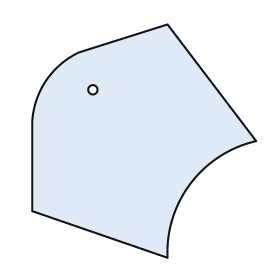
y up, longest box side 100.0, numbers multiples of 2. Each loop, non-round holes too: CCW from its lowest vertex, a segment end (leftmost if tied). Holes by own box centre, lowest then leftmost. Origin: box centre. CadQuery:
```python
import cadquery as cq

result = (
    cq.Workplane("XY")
    .moveTo(10.0, -50.0)
    .threePointArc((20.0, -18.0), (48.0, 0.0))
    .lineTo(10.0, 50.0)
    .lineTo(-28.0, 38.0)
    .threePointArc((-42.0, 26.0), (-48.0, 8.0))
    .lineTo(-48.0, -30.0)
    .close()
    .moveTo(-22.0, 22.0)
    .circle(2.0)
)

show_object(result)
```